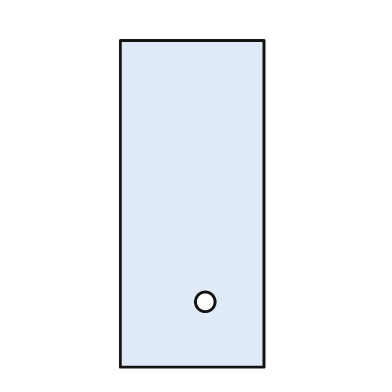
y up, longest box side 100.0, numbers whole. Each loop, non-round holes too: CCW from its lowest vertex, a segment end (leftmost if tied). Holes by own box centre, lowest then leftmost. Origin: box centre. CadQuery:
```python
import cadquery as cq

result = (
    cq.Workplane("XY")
    .moveTo(-22.0, -50.0)
    .lineTo(22.0, -50.0)
    .lineTo(22.0, 50.0)
    .lineTo(-22.0, 50.0)
    .close()
    .moveTo(4.0, -30.0)
    .circle(3.0)
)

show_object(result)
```